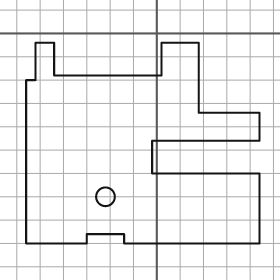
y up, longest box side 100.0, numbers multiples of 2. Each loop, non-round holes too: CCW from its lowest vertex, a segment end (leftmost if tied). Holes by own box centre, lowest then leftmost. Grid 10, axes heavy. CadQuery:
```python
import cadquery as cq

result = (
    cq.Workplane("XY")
    .moveTo(-56.0, -90.0)
    .lineTo(-30.0, -90.0)
    .lineTo(-30.0, -86.0)
    .lineTo(-14.0, -86.0)
    .lineTo(-14.0, -90.0)
    .lineTo(44.0, -90.0)
    .lineTo(44.0, -60.0)
    .lineTo(-2.0, -60.0)
    .lineTo(-2.0, -46.0)
    .lineTo(44.0, -46.0)
    .lineTo(44.0, -34.0)
    .lineTo(18.0, -34.0)
    .lineTo(18.0, -4.0)
    .lineTo(2.0, -4.0)
    .lineTo(2.0, -18.0)
    .lineTo(-44.0, -18.0)
    .lineTo(-44.0, -4.0)
    .lineTo(-52.0, -4.0)
    .lineTo(-52.0, -20.0)
    .lineTo(-56.0, -20.0)
    .close()
    .moveTo(-22.0, -70.0)
    .circle(4.0)
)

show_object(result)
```